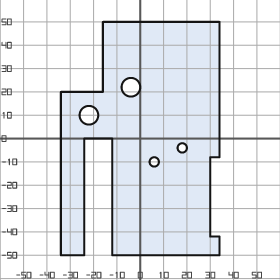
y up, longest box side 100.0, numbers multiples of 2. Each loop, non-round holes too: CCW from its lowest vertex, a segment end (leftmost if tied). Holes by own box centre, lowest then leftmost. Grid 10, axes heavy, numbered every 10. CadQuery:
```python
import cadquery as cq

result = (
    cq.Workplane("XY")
    .moveTo(-34.0, -50.0)
    .lineTo(-24.0, -50.0)
    .lineTo(-24.0, 0.0)
    .lineTo(-12.0, 0.0)
    .lineTo(-12.0, -50.0)
    .lineTo(34.0, -50.0)
    .lineTo(34.0, -42.0)
    .lineTo(30.0, -42.0)
    .lineTo(30.0, -8.0)
    .lineTo(34.0, -8.0)
    .lineTo(34.0, 50.0)
    .lineTo(-16.0, 50.0)
    .lineTo(-16.0, 20.0)
    .lineTo(-34.0, 20.0)
    .close()
    .moveTo(6.0, -10.0)
    .circle(2.0)
    .moveTo(18.0, -4.0)
    .circle(2.0)
    .moveTo(-22.0, 10.0)
    .circle(4.0)
    .moveTo(-4.0, 22.0)
    .circle(4.0)
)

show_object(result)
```